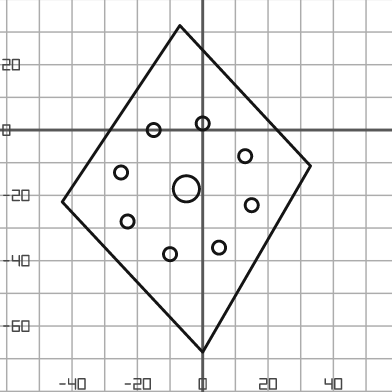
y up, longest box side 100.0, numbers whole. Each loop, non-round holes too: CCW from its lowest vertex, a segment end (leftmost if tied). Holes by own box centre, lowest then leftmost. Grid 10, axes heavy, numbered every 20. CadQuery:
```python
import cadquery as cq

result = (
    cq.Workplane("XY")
    .moveTo(0.0, -68.0)
    .lineTo(33.0, -11.0)
    .lineTo(-7.0, 32.0)
    .lineTo(-43.0, -22.0)
    .close()
    .moveTo(-10.0, -38.0)
    .circle(2.0)
    .moveTo(5.0, -36.0)
    .circle(2.0)
    .moveTo(-23.0, -28.0)
    .circle(2.0)
    .moveTo(15.0, -23.0)
    .circle(2.0)
    .moveTo(-5.0, -18.0)
    .circle(4.0)
    .moveTo(-25.0, -13.0)
    .circle(2.0)
    .moveTo(13.0, -8.0)
    .circle(2.0)
    .moveTo(-15.0, 0.0)
    .circle(2.0)
    .moveTo(0.0, 2.0)
    .circle(2.0)
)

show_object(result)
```